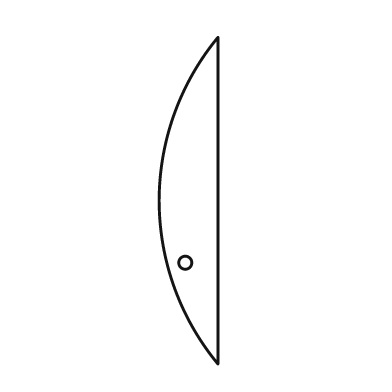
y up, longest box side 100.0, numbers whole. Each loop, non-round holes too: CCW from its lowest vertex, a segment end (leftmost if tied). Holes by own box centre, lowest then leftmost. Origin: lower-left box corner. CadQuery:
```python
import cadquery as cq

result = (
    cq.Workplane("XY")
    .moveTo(18.0, 0.0)
    .lineTo(18.0, 100.0)
    .threePointArc((0.0, 50.0), (18.0, 0.0))
    .close()
    .moveTo(8.0, 31.0)
    .circle(2.0)
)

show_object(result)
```